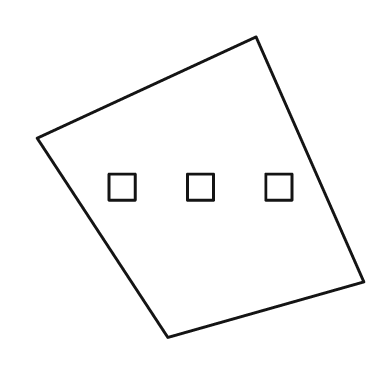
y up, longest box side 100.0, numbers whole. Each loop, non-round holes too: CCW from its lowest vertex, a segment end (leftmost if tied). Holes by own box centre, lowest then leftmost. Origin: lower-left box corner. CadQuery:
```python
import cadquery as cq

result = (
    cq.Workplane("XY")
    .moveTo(40.0, 0.0)
    .lineTo(100.0, 17.0)
    .lineTo(67.0, 92.0)
    .lineTo(0.0, 61.0)
    .close()
    .moveTo(22.0, 42.0)
    .lineTo(30.0, 42.0)
    .lineTo(30.0, 50.0)
    .lineTo(22.0, 50.0)
    .close()
    .moveTo(46.0, 42.0)
    .lineTo(54.0, 42.0)
    .lineTo(54.0, 50.0)
    .lineTo(46.0, 50.0)
    .close()
    .moveTo(70.0, 42.0)
    .lineTo(78.0, 42.0)
    .lineTo(78.0, 50.0)
    .lineTo(70.0, 50.0)
    .close()
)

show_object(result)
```